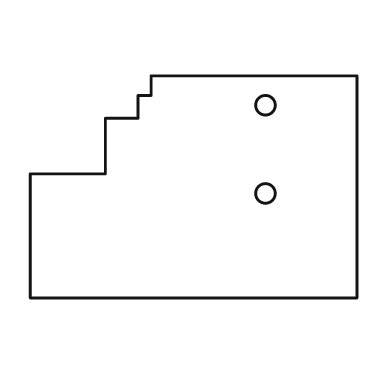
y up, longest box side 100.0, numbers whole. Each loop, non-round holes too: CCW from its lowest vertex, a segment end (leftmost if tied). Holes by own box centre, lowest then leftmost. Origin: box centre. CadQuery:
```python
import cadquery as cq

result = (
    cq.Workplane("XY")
    .moveTo(-50.0, -34.0)
    .lineTo(50.0, -34.0)
    .lineTo(50.0, 34.0)
    .lineTo(-13.0, 34.0)
    .lineTo(-13.0, 28.0)
    .lineTo(-17.0, 28.0)
    .lineTo(-17.0, 21.0)
    .lineTo(-27.0, 21.0)
    .lineTo(-27.0, 4.0)
    .lineTo(-50.0, 4.0)
    .close()
    .moveTo(22.0, -2.0)
    .circle(3.0)
    .moveTo(22.0, 25.0)
    .circle(3.0)
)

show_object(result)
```